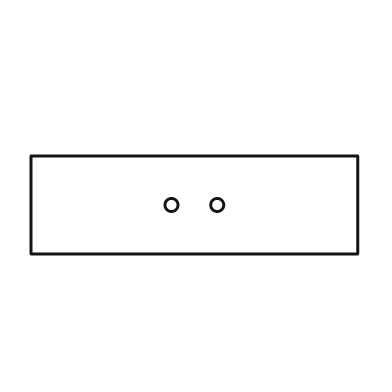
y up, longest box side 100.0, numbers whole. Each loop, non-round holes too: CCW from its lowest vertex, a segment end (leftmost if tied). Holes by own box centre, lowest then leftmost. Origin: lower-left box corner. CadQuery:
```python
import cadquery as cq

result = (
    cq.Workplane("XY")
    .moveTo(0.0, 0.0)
    .lineTo(100.0, 0.0)
    .lineTo(100.0, 30.0)
    .lineTo(0.0, 30.0)
    .close()
    .moveTo(43.0, 15.0)
    .circle(2.0)
    .moveTo(57.0, 15.0)
    .circle(2.0)
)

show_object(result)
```